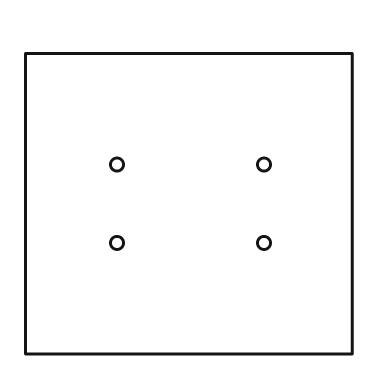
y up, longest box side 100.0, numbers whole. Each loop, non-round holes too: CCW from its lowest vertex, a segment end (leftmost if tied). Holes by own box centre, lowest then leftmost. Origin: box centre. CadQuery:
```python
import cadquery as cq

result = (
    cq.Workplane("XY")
    .moveTo(-50.0, -46.0)
    .lineTo(50.0, -46.0)
    .lineTo(50.0, 46.0)
    .lineTo(-50.0, 46.0)
    .close()
    .moveTo(-22.0, -12.0)
    .circle(2.0)
    .moveTo(23.0, -12.0)
    .circle(2.0)
    .moveTo(-22.0, 12.0)
    .circle(2.0)
    .moveTo(23.0, 12.0)
    .circle(2.0)
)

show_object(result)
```